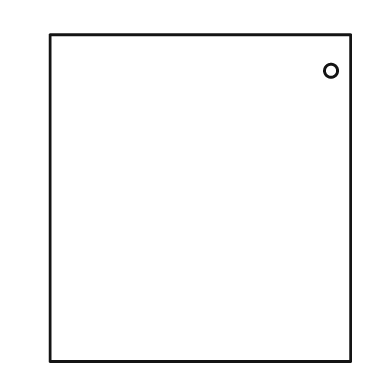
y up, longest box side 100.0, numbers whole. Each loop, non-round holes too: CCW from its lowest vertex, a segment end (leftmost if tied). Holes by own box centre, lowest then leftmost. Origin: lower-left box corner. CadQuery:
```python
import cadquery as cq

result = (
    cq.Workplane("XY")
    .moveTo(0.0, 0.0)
    .lineTo(92.0, 0.0)
    .lineTo(92.0, 100.0)
    .lineTo(0.0, 100.0)
    .close()
    .moveTo(86.0, 89.0)
    .circle(2.0)
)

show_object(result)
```